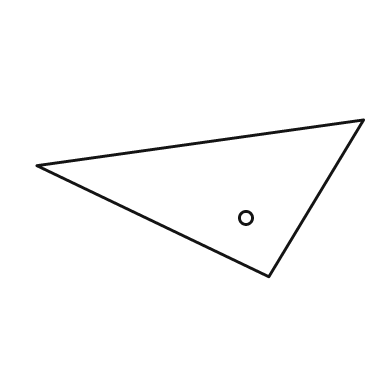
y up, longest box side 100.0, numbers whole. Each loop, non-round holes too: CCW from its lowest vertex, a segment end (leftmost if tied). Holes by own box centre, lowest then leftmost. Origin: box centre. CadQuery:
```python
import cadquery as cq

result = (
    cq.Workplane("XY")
    .moveTo(21.0, -24.0)
    .lineTo(50.0, 24.0)
    .lineTo(-50.0, 10.0)
    .close()
    .moveTo(14.0, -6.0)
    .circle(2.0)
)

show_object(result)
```